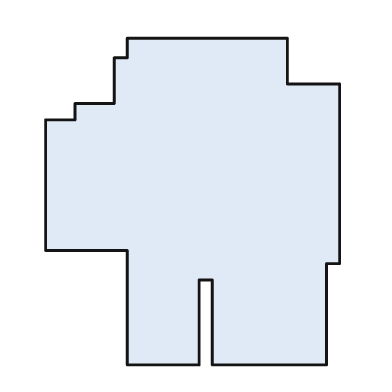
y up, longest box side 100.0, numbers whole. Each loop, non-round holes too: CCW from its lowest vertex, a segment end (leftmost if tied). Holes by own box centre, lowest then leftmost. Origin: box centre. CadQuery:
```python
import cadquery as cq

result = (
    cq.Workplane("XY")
    .moveTo(-20.0, -50.0)
    .lineTo(2.0, -50.0)
    .lineTo(2.0, -24.0)
    .lineTo(6.0, -24.0)
    .lineTo(6.0, -50.0)
    .lineTo(41.0, -50.0)
    .lineTo(41.0, -19.0)
    .lineTo(45.0, -19.0)
    .lineTo(45.0, 36.0)
    .lineTo(29.0, 36.0)
    .lineTo(29.0, 50.0)
    .lineTo(-20.0, 50.0)
    .lineTo(-20.0, 44.0)
    .lineTo(-24.0, 44.0)
    .lineTo(-24.0, 30.0)
    .lineTo(-36.0, 30.0)
    .lineTo(-36.0, 25.0)
    .lineTo(-45.0, 25.0)
    .lineTo(-45.0, -15.0)
    .lineTo(-20.0, -15.0)
    .close()
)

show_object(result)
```